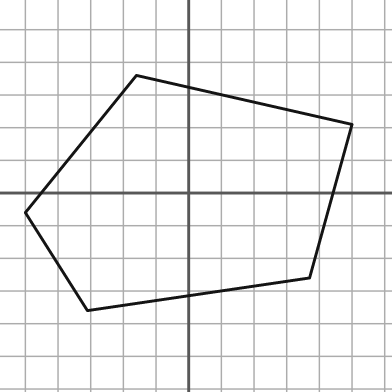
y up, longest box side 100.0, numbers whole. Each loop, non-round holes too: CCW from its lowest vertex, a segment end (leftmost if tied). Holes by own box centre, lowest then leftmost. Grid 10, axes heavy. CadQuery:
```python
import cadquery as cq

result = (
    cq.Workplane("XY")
    .moveTo(-31.0, -36.0)
    .lineTo(37.0, -26.0)
    .lineTo(50.0, 21.0)
    .lineTo(-16.0, 36.0)
    .lineTo(-50.0, -6.0)
    .close()
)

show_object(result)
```